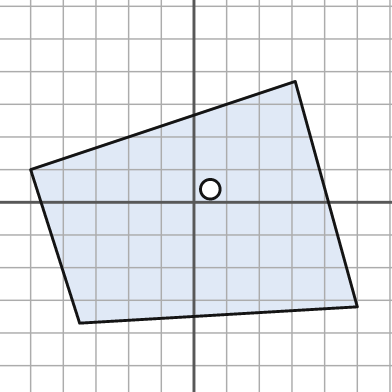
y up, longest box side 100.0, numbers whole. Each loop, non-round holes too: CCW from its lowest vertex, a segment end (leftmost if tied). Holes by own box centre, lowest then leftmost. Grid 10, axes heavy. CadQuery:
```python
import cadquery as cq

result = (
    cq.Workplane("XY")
    .moveTo(-35.0, -37.0)
    .lineTo(50.0, -32.0)
    .lineTo(31.0, 37.0)
    .lineTo(-50.0, 10.0)
    .close()
    .moveTo(5.0, 4.0)
    .circle(3.0)
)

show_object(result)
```